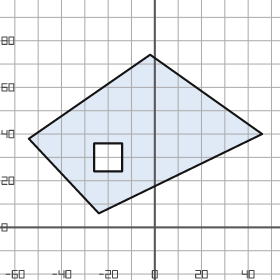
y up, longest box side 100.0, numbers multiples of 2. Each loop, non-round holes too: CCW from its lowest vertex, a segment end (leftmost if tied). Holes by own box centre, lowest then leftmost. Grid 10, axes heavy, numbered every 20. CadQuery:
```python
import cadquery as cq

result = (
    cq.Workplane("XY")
    .moveTo(-24.0, 6.0)
    .lineTo(46.0, 40.0)
    .lineTo(-2.0, 74.0)
    .lineTo(-54.0, 38.0)
    .close()
    .moveTo(-26.0, 24.0)
    .lineTo(-14.0, 24.0)
    .lineTo(-14.0, 36.0)
    .lineTo(-26.0, 36.0)
    .close()
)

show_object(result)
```